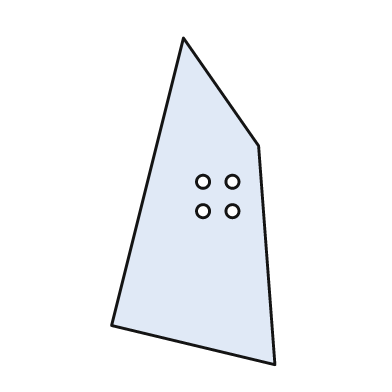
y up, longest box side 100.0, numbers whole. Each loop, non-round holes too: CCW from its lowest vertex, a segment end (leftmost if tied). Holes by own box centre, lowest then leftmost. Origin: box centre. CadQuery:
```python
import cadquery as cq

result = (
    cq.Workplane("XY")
    .moveTo(25.0, -50.0)
    .lineTo(20.0, 17.0)
    .lineTo(-3.0, 50.0)
    .lineTo(-25.0, -38.0)
    .close()
    .moveTo(3.0, -3.0)
    .circle(2.0)
    .moveTo(12.0, -3.0)
    .circle(2.0)
    .moveTo(3.0, 6.0)
    .circle(2.0)
    .moveTo(12.0, 6.0)
    .circle(2.0)
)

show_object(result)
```